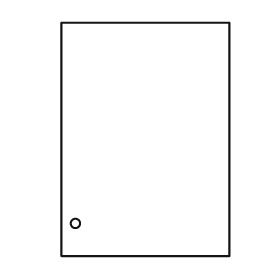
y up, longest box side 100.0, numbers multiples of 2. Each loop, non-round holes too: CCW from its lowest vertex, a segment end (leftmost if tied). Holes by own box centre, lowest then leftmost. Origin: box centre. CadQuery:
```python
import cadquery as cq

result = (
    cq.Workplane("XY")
    .moveTo(-36.0, -50.0)
    .lineTo(36.0, -50.0)
    .lineTo(36.0, 50.0)
    .lineTo(-36.0, 50.0)
    .close()
    .moveTo(-30.0, -36.0)
    .circle(2.0)
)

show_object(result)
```